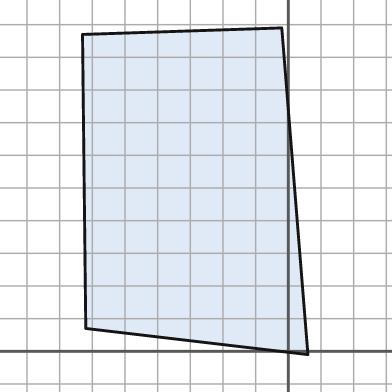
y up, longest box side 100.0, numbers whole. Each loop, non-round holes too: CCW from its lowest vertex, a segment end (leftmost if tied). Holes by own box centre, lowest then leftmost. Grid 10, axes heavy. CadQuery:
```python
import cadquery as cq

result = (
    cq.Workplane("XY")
    .moveTo(6.0, -1.0)
    .lineTo(-2.0, 99.0)
    .lineTo(-63.0, 97.0)
    .lineTo(-62.0, 7.0)
    .close()
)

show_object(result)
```